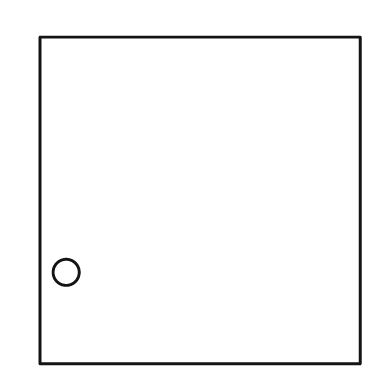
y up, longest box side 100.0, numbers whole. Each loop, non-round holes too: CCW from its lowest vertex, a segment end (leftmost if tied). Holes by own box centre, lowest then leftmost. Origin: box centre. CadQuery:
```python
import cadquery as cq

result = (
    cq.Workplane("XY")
    .moveTo(-49.0, -50.0)
    .lineTo(49.0, -50.0)
    .lineTo(49.0, 50.0)
    .lineTo(-49.0, 50.0)
    .close()
    .moveTo(-41.0, -22.0)
    .circle(4.0)
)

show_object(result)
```